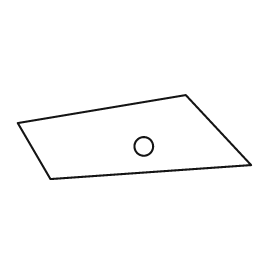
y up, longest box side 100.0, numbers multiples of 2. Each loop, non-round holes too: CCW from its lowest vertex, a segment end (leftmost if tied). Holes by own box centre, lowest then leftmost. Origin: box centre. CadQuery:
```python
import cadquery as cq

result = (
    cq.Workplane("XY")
    .moveTo(-36.0, -18.0)
    .lineTo(50.0, -12.0)
    .lineTo(22.0, 18.0)
    .lineTo(-50.0, 6.0)
    .close()
    .moveTo(4.0, -4.0)
    .circle(4.0)
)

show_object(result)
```